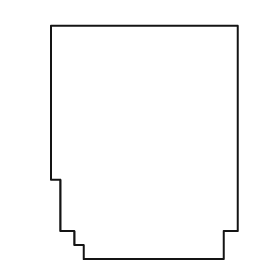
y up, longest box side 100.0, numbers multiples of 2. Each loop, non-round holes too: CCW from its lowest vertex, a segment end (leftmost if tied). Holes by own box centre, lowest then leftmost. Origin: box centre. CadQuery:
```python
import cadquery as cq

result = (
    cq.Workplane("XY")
    .moveTo(-26.0, -50.0)
    .lineTo(34.0, -50.0)
    .lineTo(34.0, -38.0)
    .lineTo(40.0, -38.0)
    .lineTo(40.0, 50.0)
    .lineTo(-40.0, 50.0)
    .lineTo(-40.0, -16.0)
    .lineTo(-36.0, -16.0)
    .lineTo(-36.0, -38.0)
    .lineTo(-30.0, -38.0)
    .lineTo(-30.0, -44.0)
    .lineTo(-26.0, -44.0)
    .close()
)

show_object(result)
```